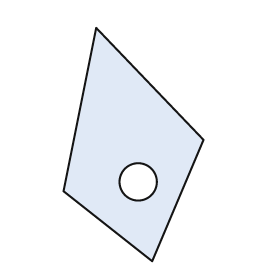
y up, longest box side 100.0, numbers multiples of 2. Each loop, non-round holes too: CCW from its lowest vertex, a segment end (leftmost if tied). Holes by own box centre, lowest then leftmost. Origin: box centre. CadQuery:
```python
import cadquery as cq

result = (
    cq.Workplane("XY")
    .moveTo(8.0, -50.0)
    .lineTo(30.0, 2.0)
    .lineTo(-16.0, 50.0)
    .lineTo(-30.0, -20.0)
    .close()
    .moveTo(2.0, -16.0)
    .circle(8.0)
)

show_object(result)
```